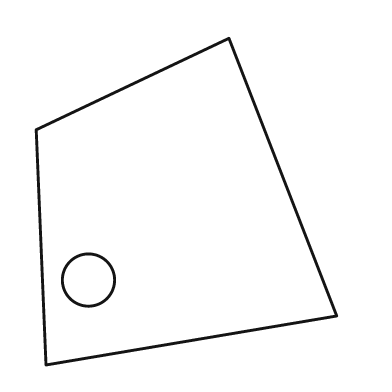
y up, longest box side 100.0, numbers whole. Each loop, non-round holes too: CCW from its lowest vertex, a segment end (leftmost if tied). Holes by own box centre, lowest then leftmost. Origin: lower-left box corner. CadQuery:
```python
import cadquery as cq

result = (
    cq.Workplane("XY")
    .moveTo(3.0, 0.0)
    .lineTo(92.0, 15.0)
    .lineTo(59.0, 100.0)
    .lineTo(0.0, 72.0)
    .close()
    .moveTo(16.0, 26.0)
    .circle(8.0)
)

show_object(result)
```